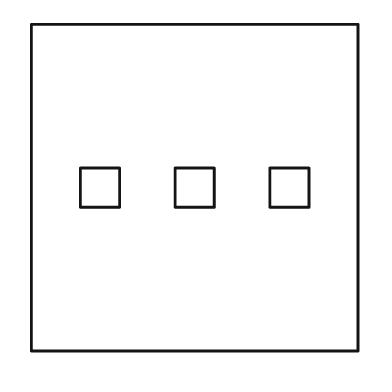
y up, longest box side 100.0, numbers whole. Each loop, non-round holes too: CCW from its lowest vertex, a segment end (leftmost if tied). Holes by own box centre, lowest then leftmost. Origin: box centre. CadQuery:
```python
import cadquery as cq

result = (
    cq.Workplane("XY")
    .moveTo(-50.0, -50.0)
    .lineTo(50.0, -50.0)
    .lineTo(50.0, 50.0)
    .lineTo(-50.0, 50.0)
    .close()
    .moveTo(-35.0, -6.0)
    .lineTo(-23.0, -6.0)
    .lineTo(-23.0, 6.0)
    .lineTo(-35.0, 6.0)
    .close()
    .moveTo(-6.0, -6.0)
    .lineTo(6.0, -6.0)
    .lineTo(6.0, 6.0)
    .lineTo(-6.0, 6.0)
    .close()
    .moveTo(23.0, -6.0)
    .lineTo(35.0, -6.0)
    .lineTo(35.0, 6.0)
    .lineTo(23.0, 6.0)
    .close()
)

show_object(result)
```